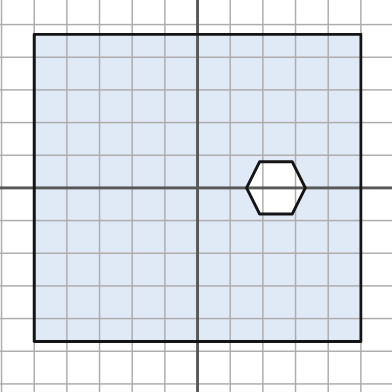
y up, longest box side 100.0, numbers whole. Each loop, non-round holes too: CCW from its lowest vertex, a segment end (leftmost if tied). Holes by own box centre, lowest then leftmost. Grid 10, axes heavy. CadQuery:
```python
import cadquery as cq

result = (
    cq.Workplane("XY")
    .moveTo(-50.0, -47.0)
    .lineTo(50.0, -47.0)
    .lineTo(50.0, 47.0)
    .lineTo(-50.0, 47.0)
    .close()
    .moveTo(19.0, -8.0)
    .lineTo(29.0, -8.0)
    .lineTo(33.0, 0.0)
    .lineTo(29.0, 8.0)
    .lineTo(19.0, 8.0)
    .lineTo(15.0, 0.0)
    .close()
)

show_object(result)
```